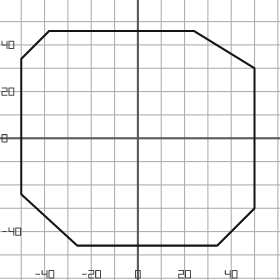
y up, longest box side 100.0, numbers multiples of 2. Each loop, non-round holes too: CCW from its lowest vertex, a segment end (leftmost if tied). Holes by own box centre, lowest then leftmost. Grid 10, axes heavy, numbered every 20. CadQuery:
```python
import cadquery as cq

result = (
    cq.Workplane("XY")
    .moveTo(-26.0, -46.0)
    .lineTo(34.0, -46.0)
    .lineTo(50.0, -30.0)
    .lineTo(50.0, 30.0)
    .lineTo(24.0, 46.0)
    .lineTo(-38.0, 46.0)
    .lineTo(-50.0, 34.0)
    .lineTo(-50.0, -24.0)
    .close()
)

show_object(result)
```